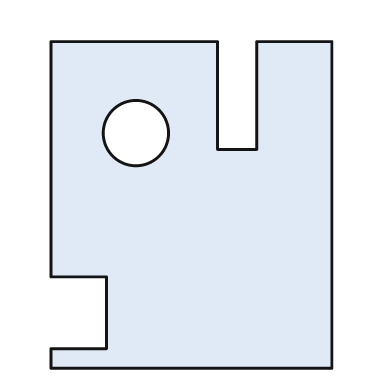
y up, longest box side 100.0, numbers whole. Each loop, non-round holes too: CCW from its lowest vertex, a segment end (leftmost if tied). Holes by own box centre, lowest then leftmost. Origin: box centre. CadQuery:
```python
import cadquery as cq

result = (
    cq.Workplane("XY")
    .moveTo(-43.0, -50.0)
    .lineTo(43.0, -50.0)
    .lineTo(43.0, 50.0)
    .lineTo(20.0, 50.0)
    .lineTo(20.0, 17.0)
    .lineTo(8.0, 17.0)
    .lineTo(8.0, 50.0)
    .lineTo(-43.0, 50.0)
    .lineTo(-43.0, -22.0)
    .lineTo(-26.0, -22.0)
    .lineTo(-26.0, -44.0)
    .lineTo(-43.0, -44.0)
    .close()
    .moveTo(-17.0, 22.0)
    .circle(10.0)
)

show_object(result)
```